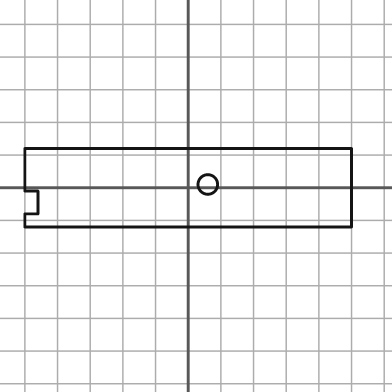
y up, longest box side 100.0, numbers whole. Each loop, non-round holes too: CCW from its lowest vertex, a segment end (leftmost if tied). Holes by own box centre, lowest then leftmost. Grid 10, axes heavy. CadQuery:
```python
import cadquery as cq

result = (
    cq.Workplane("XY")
    .moveTo(-50.0, -12.0)
    .lineTo(50.0, -12.0)
    .lineTo(50.0, 12.0)
    .lineTo(-50.0, 12.0)
    .lineTo(-50.0, -1.0)
    .lineTo(-46.0, -1.0)
    .lineTo(-46.0, -8.0)
    .lineTo(-50.0, -8.0)
    .close()
    .moveTo(6.0, 1.0)
    .circle(3.0)
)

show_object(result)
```